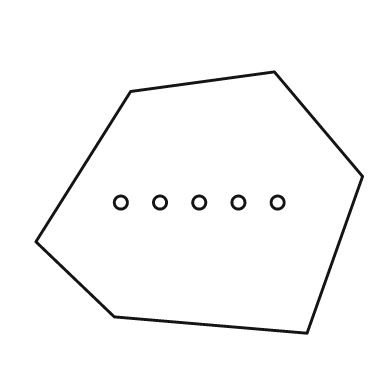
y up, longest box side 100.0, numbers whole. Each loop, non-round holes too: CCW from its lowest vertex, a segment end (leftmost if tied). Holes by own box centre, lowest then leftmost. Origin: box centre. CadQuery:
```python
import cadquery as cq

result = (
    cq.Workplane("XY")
    .moveTo(33.0, -40.0)
    .lineTo(50.0, 8.0)
    .lineTo(23.0, 40.0)
    .lineTo(-21.0, 34.0)
    .lineTo(-50.0, -12.0)
    .lineTo(-26.0, -35.0)
    .close()
    .moveTo(-24.0, 0.0)
    .circle(2.0)
    .moveTo(-12.0, 0.0)
    .circle(2.0)
    .moveTo(0.0, 0.0)
    .circle(2.0)
    .moveTo(12.0, 0.0)
    .circle(2.0)
    .moveTo(24.0, 0.0)
    .circle(2.0)
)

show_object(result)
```